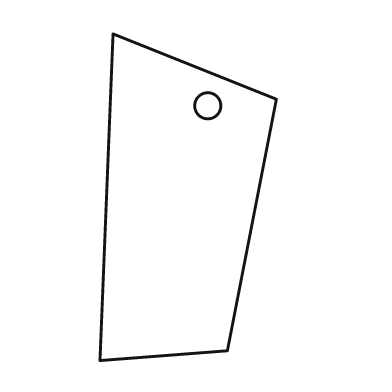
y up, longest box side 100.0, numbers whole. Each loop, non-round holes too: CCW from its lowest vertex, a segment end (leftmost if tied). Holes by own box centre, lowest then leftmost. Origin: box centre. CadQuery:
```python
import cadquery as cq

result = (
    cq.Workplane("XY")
    .moveTo(-27.0, -50.0)
    .lineTo(12.0, -47.0)
    .lineTo(27.0, 30.0)
    .lineTo(-23.0, 50.0)
    .close()
    .moveTo(6.0, 28.0)
    .circle(4.0)
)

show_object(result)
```